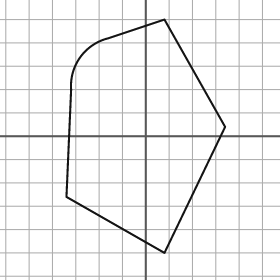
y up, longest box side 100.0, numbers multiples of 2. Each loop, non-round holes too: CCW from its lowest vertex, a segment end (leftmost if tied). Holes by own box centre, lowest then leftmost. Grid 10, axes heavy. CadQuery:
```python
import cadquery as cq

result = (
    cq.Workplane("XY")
    .moveTo(8.0, -50.0)
    .lineTo(34.0, 4.0)
    .lineTo(8.0, 50.0)
    .lineTo(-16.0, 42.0)
    .threePointArc((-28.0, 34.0), (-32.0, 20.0))
    .lineTo(-34.0, -26.0)
    .close()
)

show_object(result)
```